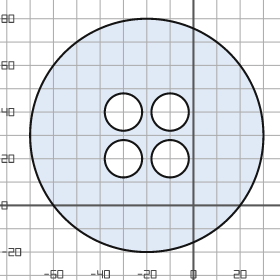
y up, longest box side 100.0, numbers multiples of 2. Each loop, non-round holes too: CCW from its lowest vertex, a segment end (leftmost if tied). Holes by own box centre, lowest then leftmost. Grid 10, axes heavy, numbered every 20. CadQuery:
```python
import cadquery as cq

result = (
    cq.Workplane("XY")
    .moveTo(-20.0, 30.0)
    .circle(50.0)
    .moveTo(-30.0, 20.0)
    .circle(8.0)
    .moveTo(-10.0, 20.0)
    .circle(8.0)
    .moveTo(-30.0, 40.0)
    .circle(8.0)
    .moveTo(-10.0, 40.0)
    .circle(8.0)
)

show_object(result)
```